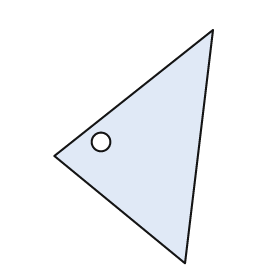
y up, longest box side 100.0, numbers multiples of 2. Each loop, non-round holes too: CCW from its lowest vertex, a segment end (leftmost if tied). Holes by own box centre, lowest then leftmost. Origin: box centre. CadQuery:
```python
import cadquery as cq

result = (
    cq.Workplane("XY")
    .moveTo(22.0, -50.0)
    .lineTo(34.0, 50.0)
    .lineTo(-34.0, -4.0)
    .close()
    .moveTo(-14.0, 2.0)
    .circle(4.0)
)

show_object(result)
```